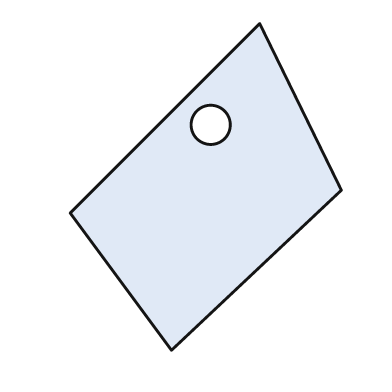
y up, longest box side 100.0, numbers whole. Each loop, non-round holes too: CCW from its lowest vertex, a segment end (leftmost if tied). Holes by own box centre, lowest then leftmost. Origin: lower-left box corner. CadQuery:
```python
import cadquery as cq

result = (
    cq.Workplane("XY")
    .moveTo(31.0, 0.0)
    .lineTo(83.0, 49.0)
    .lineTo(58.0, 100.0)
    .lineTo(0.0, 42.0)
    .close()
    .moveTo(43.0, 69.0)
    .circle(6.0)
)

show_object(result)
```